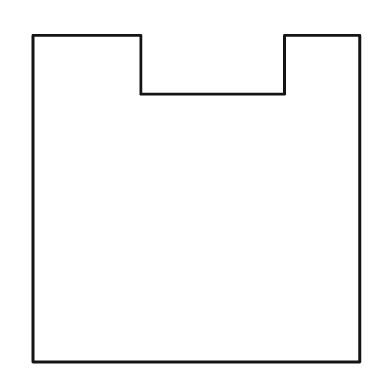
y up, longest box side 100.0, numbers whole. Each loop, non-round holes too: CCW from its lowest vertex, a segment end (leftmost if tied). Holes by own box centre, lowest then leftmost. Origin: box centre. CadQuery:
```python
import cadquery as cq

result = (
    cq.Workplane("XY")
    .moveTo(-50.0, -50.0)
    .lineTo(50.0, -50.0)
    .lineTo(50.0, 50.0)
    .lineTo(27.0, 50.0)
    .lineTo(27.0, 32.0)
    .lineTo(-17.0, 32.0)
    .lineTo(-17.0, 50.0)
    .lineTo(-50.0, 50.0)
    .close()
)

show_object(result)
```